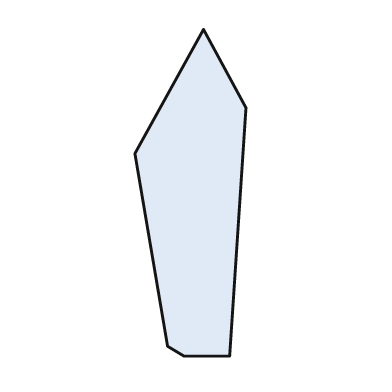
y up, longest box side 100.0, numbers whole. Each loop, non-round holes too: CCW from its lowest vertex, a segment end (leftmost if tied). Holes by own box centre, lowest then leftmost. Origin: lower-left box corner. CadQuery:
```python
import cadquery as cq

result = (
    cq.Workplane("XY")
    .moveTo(15.0, 0.0)
    .lineTo(29.0, 0.0)
    .lineTo(34.0, 76.0)
    .lineTo(21.0, 100.0)
    .lineTo(0.0, 62.0)
    .lineTo(10.0, 3.0)
    .close()
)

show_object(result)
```